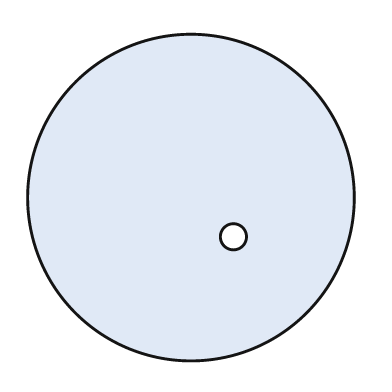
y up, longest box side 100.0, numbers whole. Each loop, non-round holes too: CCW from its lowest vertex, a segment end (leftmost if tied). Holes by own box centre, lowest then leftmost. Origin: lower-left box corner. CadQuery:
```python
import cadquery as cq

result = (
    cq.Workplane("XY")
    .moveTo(50.0, 50.0)
    .circle(50.0)
    .moveTo(63.0, 38.0)
    .circle(4.0)
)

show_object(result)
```